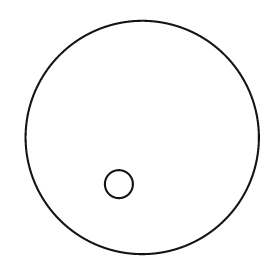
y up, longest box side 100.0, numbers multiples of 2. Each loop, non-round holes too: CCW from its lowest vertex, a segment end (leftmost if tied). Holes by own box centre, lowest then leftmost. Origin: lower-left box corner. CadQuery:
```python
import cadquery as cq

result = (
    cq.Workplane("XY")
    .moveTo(50.0, 50.0)
    .circle(50.0)
    .moveTo(40.0, 30.0)
    .circle(6.0)
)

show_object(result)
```